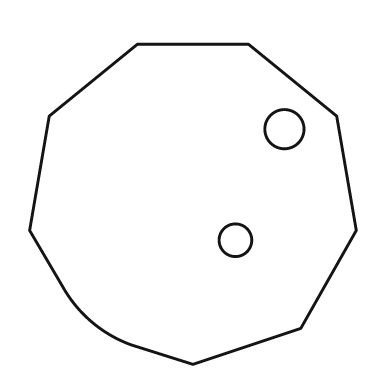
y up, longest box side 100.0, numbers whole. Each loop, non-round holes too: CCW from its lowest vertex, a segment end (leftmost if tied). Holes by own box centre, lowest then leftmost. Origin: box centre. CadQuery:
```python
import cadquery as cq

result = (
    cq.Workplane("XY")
    .moveTo(0.0, -49.0)
    .lineTo(33.0, -38.0)
    .lineTo(50.0, -8.0)
    .lineTo(44.0, 27.0)
    .lineTo(17.0, 49.0)
    .lineTo(-17.0, 49.0)
    .lineTo(-44.0, 27.0)
    .lineTo(-50.0, -8.0)
    .lineTo(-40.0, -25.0)
    .threePointArc((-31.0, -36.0), (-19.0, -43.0))
    .close()
    .moveTo(13.0, -11.0)
    .circle(5.0)
    .moveTo(28.0, 23.0)
    .circle(6.0)
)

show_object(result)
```